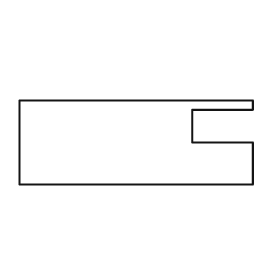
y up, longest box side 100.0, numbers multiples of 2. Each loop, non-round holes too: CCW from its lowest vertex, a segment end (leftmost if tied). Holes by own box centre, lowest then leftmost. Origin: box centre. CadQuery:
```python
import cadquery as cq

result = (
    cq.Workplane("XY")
    .moveTo(-50.0, -18.0)
    .lineTo(50.0, -18.0)
    .lineTo(50.0, 0.0)
    .lineTo(24.0, 0.0)
    .lineTo(24.0, 14.0)
    .lineTo(50.0, 14.0)
    .lineTo(50.0, 18.0)
    .lineTo(-50.0, 18.0)
    .close()
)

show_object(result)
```